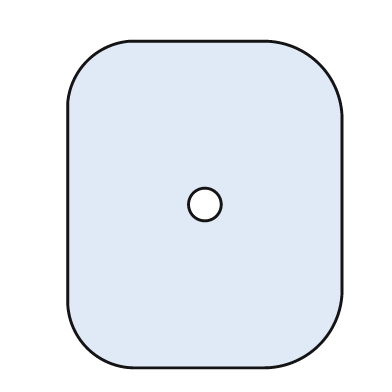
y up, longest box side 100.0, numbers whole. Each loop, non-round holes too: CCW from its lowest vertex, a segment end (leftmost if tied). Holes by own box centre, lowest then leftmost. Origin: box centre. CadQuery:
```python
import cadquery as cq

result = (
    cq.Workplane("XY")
    .moveTo(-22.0, -50.0)
    .lineTo(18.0, -50.0)
    .threePointArc((35.0, -43.0), (42.0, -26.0))
    .lineTo(42.0, 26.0)
    .threePointArc((35.0, 43.0), (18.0, 50.0))
    .lineTo(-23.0, 50.0)
    .threePointArc((-36.0, 44.0), (-42.0, 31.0))
    .lineTo(-42.0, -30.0)
    .threePointArc((-36.0, -44.0), (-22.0, -50.0))
    .close()
    .moveTo(0.0, 0.0)
    .circle(5.0)
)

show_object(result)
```